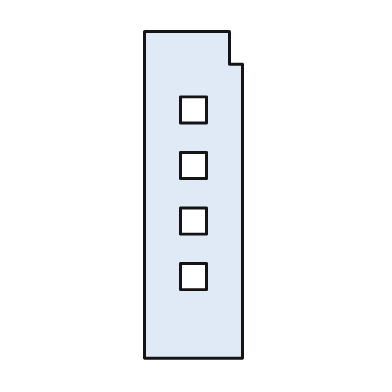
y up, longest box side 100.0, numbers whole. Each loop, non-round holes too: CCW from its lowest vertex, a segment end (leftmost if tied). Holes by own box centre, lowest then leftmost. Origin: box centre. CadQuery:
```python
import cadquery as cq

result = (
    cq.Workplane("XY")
    .moveTo(-15.0, -50.0)
    .lineTo(15.0, -50.0)
    .lineTo(15.0, 40.0)
    .lineTo(11.0, 40.0)
    .lineTo(11.0, 50.0)
    .lineTo(-15.0, 50.0)
    .close()
    .moveTo(-4.0, -29.0)
    .lineTo(4.0, -29.0)
    .lineTo(4.0, -21.0)
    .lineTo(-4.0, -21.0)
    .close()
    .moveTo(-4.0, -12.0)
    .lineTo(4.0, -12.0)
    .lineTo(4.0, -4.0)
    .lineTo(-4.0, -4.0)
    .close()
    .moveTo(-4.0, 5.0)
    .lineTo(4.0, 5.0)
    .lineTo(4.0, 13.0)
    .lineTo(-4.0, 13.0)
    .close()
    .moveTo(-4.0, 22.0)
    .lineTo(4.0, 22.0)
    .lineTo(4.0, 30.0)
    .lineTo(-4.0, 30.0)
    .close()
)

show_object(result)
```